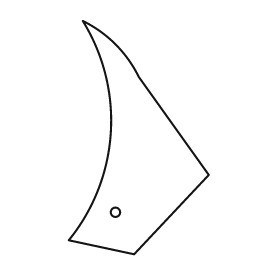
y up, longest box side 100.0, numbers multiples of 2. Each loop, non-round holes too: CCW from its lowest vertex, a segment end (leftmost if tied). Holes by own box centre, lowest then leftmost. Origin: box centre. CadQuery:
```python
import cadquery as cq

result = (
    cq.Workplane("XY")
    .moveTo(-2.0, -50.0)
    .lineTo(30.0, -16.0)
    .lineTo(0.0, 26.0)
    .threePointArc((-10.0, 40.0), (-24.0, 50.0))
    .threePointArc((-12.0, 2.0), (-30.0, -44.0))
    .close()
    .moveTo(-10.0, -32.0)
    .circle(2.0)
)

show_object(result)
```